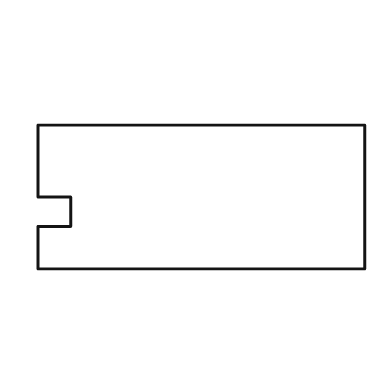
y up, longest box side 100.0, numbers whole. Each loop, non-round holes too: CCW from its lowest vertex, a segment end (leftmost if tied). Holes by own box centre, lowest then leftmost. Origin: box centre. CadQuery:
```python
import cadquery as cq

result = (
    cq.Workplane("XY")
    .moveTo(-50.0, -22.0)
    .lineTo(50.0, -22.0)
    .lineTo(50.0, 22.0)
    .lineTo(-50.0, 22.0)
    .lineTo(-50.0, 0.0)
    .lineTo(-40.0, 0.0)
    .lineTo(-40.0, -9.0)
    .lineTo(-50.0, -9.0)
    .close()
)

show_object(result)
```